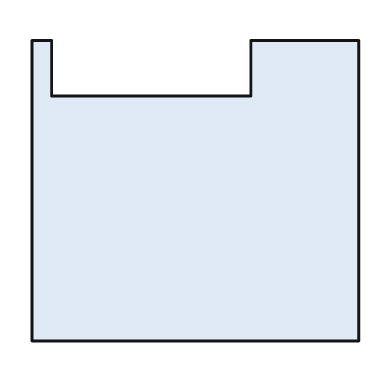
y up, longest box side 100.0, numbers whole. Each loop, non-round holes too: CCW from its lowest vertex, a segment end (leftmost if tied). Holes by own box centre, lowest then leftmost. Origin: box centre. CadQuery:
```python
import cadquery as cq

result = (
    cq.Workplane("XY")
    .moveTo(-50.0, -46.0)
    .lineTo(50.0, -46.0)
    .lineTo(50.0, 46.0)
    .lineTo(17.0, 46.0)
    .lineTo(17.0, 29.0)
    .lineTo(-44.0, 29.0)
    .lineTo(-44.0, 46.0)
    .lineTo(-50.0, 46.0)
    .close()
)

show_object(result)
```